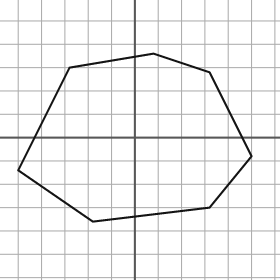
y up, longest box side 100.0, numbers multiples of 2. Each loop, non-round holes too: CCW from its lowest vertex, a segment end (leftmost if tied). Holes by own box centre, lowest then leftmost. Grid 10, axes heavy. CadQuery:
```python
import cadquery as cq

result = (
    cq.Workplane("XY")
    .moveTo(-18.0, -36.0)
    .lineTo(32.0, -30.0)
    .lineTo(50.0, -8.0)
    .lineTo(32.0, 28.0)
    .lineTo(8.0, 36.0)
    .lineTo(-28.0, 30.0)
    .lineTo(-50.0, -14.0)
    .close()
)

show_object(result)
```